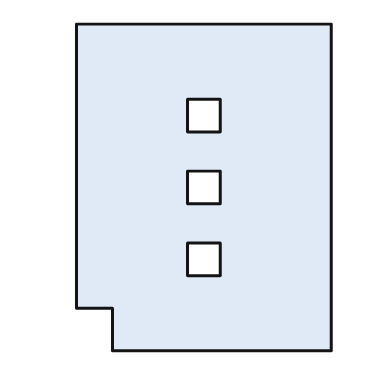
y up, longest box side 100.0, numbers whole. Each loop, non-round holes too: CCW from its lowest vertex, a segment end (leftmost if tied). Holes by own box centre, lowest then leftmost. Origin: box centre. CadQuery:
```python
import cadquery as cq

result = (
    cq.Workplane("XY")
    .moveTo(-28.0, -50.0)
    .lineTo(39.0, -50.0)
    .lineTo(39.0, 50.0)
    .lineTo(-39.0, 50.0)
    .lineTo(-39.0, -37.0)
    .lineTo(-28.0, -37.0)
    .close()
    .moveTo(-5.0, -27.0)
    .lineTo(5.0, -27.0)
    .lineTo(5.0, -17.0)
    .lineTo(-5.0, -17.0)
    .close()
    .moveTo(-5.0, -5.0)
    .lineTo(5.0, -5.0)
    .lineTo(5.0, 5.0)
    .lineTo(-5.0, 5.0)
    .close()
    .moveTo(-5.0, 17.0)
    .lineTo(5.0, 17.0)
    .lineTo(5.0, 27.0)
    .lineTo(-5.0, 27.0)
    .close()
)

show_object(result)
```